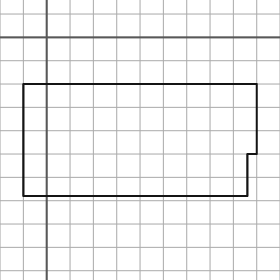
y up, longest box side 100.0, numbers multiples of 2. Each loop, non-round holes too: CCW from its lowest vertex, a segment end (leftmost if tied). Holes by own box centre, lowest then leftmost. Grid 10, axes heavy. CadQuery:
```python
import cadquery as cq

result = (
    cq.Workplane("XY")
    .moveTo(-10.0, -68.0)
    .lineTo(86.0, -68.0)
    .lineTo(86.0, -50.0)
    .lineTo(90.0, -50.0)
    .lineTo(90.0, -20.0)
    .lineTo(-10.0, -20.0)
    .close()
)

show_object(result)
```